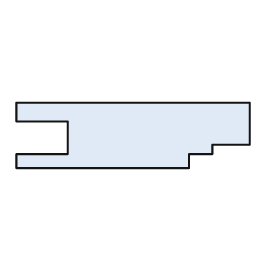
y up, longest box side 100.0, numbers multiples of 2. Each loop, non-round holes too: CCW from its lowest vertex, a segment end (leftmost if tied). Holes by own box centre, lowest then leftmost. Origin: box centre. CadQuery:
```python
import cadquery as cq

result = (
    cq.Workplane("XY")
    .moveTo(-50.0, -14.0)
    .lineTo(24.0, -14.0)
    .lineTo(24.0, -8.0)
    .lineTo(34.0, -8.0)
    .lineTo(34.0, -4.0)
    .lineTo(50.0, -4.0)
    .lineTo(50.0, 14.0)
    .lineTo(-50.0, 14.0)
    .lineTo(-50.0, 6.0)
    .lineTo(-28.0, 6.0)
    .lineTo(-28.0, -8.0)
    .lineTo(-50.0, -8.0)
    .close()
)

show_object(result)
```